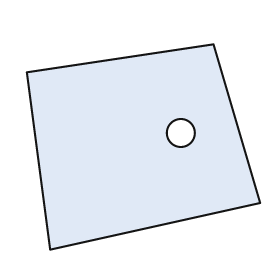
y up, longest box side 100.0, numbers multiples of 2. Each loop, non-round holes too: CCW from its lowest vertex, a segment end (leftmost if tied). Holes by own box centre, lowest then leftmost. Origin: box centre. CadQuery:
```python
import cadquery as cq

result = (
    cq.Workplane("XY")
    .moveTo(-40.0, -44.0)
    .lineTo(50.0, -24.0)
    .lineTo(30.0, 44.0)
    .lineTo(-50.0, 32.0)
    .close()
    .moveTo(16.0, 6.0)
    .circle(6.0)
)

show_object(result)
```